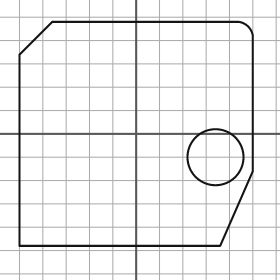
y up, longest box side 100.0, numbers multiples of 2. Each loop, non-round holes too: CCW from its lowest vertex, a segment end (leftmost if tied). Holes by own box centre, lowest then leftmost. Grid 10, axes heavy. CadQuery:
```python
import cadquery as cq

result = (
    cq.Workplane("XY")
    .moveTo(-50.0, -48.0)
    .lineTo(36.0, -48.0)
    .lineTo(50.0, -16.0)
    .lineTo(50.0, 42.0)
    .threePointArc((48.0, 46.0), (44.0, 48.0))
    .lineTo(-36.0, 48.0)
    .lineTo(-50.0, 34.0)
    .close()
    .moveTo(34.0, -10.0)
    .circle(12.0)
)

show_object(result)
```